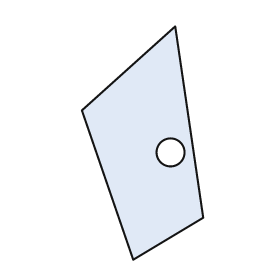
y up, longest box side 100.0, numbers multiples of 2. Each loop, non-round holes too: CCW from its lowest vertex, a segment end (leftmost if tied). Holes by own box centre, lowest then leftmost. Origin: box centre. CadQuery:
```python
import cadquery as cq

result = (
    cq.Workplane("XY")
    .moveTo(-4.0, -50.0)
    .lineTo(26.0, -32.0)
    .lineTo(14.0, 50.0)
    .lineTo(-26.0, 14.0)
    .close()
    .moveTo(12.0, -4.0)
    .circle(6.0)
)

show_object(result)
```